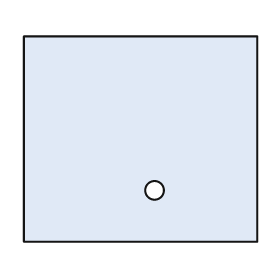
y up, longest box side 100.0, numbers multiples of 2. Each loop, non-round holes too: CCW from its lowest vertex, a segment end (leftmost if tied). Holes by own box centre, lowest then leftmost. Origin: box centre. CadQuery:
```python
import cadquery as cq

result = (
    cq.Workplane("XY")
    .moveTo(-50.0, -44.0)
    .lineTo(50.0, -44.0)
    .lineTo(50.0, 44.0)
    .lineTo(-50.0, 44.0)
    .close()
    .moveTo(6.0, -22.0)
    .circle(4.0)
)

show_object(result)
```